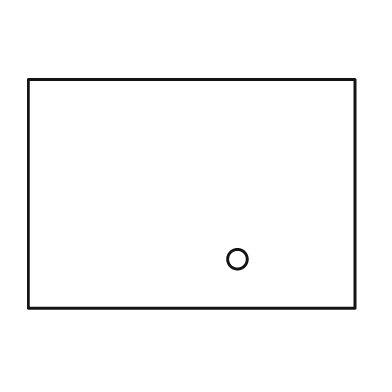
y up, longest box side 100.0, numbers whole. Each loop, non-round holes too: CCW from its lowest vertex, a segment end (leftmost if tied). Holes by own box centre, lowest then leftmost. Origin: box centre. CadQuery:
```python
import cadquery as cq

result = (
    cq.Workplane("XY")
    .moveTo(-50.0, -35.0)
    .lineTo(50.0, -35.0)
    .lineTo(50.0, 35.0)
    .lineTo(-50.0, 35.0)
    .close()
    .moveTo(14.0, -20.0)
    .circle(3.0)
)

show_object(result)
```